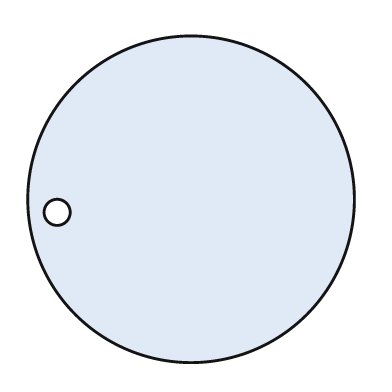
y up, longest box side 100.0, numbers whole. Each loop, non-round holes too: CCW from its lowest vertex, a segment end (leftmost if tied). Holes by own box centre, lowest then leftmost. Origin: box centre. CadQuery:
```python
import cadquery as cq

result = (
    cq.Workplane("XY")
    .moveTo(0.0, 0.0)
    .circle(50.0)
    .moveTo(-41.0, -4.0)
    .circle(4.0)
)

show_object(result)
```